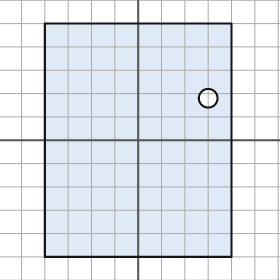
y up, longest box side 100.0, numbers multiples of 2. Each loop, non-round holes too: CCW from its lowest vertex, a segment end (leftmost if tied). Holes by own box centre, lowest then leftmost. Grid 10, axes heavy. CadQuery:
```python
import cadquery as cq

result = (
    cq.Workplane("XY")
    .moveTo(-40.0, -50.0)
    .lineTo(40.0, -50.0)
    .lineTo(40.0, 50.0)
    .lineTo(-40.0, 50.0)
    .close()
    .moveTo(30.0, 18.0)
    .circle(4.0)
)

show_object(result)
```